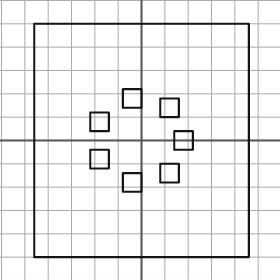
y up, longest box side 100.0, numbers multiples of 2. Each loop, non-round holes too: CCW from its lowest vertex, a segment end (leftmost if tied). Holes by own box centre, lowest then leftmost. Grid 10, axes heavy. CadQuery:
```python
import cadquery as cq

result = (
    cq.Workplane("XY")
    .moveTo(-46.0, -50.0)
    .lineTo(46.0, -50.0)
    .lineTo(46.0, 50.0)
    .lineTo(-46.0, 50.0)
    .close()
    .moveTo(-8.0, -22.0)
    .lineTo(0.0, -22.0)
    .lineTo(0.0, -14.0)
    .lineTo(-8.0, -14.0)
    .close()
    .moveTo(8.0, -18.0)
    .lineTo(16.0, -18.0)
    .lineTo(16.0, -10.0)
    .lineTo(8.0, -10.0)
    .close()
    .moveTo(-22.0, -12.0)
    .lineTo(-14.0, -12.0)
    .lineTo(-14.0, -4.0)
    .lineTo(-22.0, -4.0)
    .close()
    .moveTo(14.0, -4.0)
    .lineTo(22.0, -4.0)
    .lineTo(22.0, 4.0)
    .lineTo(14.0, 4.0)
    .close()
    .moveTo(-22.0, 4.0)
    .lineTo(-14.0, 4.0)
    .lineTo(-14.0, 12.0)
    .lineTo(-22.0, 12.0)
    .close()
    .moveTo(8.0, 10.0)
    .lineTo(16.0, 10.0)
    .lineTo(16.0, 18.0)
    .lineTo(8.0, 18.0)
    .close()
    .moveTo(-8.0, 14.0)
    .lineTo(0.0, 14.0)
    .lineTo(0.0, 22.0)
    .lineTo(-8.0, 22.0)
    .close()
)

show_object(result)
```